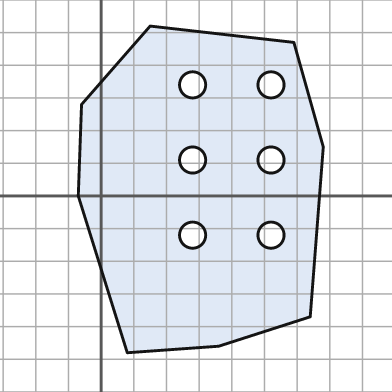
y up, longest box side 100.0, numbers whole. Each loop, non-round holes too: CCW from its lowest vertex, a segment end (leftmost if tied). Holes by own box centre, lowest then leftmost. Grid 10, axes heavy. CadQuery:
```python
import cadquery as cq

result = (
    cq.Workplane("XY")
    .moveTo(8.0, -48.0)
    .lineTo(36.0, -46.0)
    .lineTo(64.0, -37.0)
    .lineTo(68.0, 15.0)
    .lineTo(59.0, 47.0)
    .lineTo(15.0, 52.0)
    .lineTo(-6.0, 28.0)
    .lineTo(-7.0, 0.0)
    .close()
    .moveTo(28.0, -12.0)
    .circle(4.0)
    .moveTo(52.0, -12.0)
    .circle(4.0)
    .moveTo(28.0, 11.0)
    .circle(4.0)
    .moveTo(52.0, 11.0)
    .circle(4.0)
    .moveTo(28.0, 34.0)
    .circle(4.0)
    .moveTo(52.0, 34.0)
    .circle(4.0)
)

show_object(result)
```